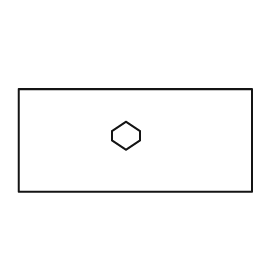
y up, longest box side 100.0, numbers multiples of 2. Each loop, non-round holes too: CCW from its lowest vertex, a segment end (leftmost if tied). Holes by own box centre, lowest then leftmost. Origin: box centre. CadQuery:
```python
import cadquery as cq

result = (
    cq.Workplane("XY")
    .moveTo(-50.0, -22.0)
    .lineTo(50.0, -22.0)
    .lineTo(50.0, 22.0)
    .lineTo(-50.0, 22.0)
    .close()
    .moveTo(-4.0, -4.0)
    .lineTo(2.0, 0.0)
    .lineTo(2.0, 4.0)
    .lineTo(-4.0, 8.0)
    .lineTo(-10.0, 4.0)
    .lineTo(-10.0, 0.0)
    .close()
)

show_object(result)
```